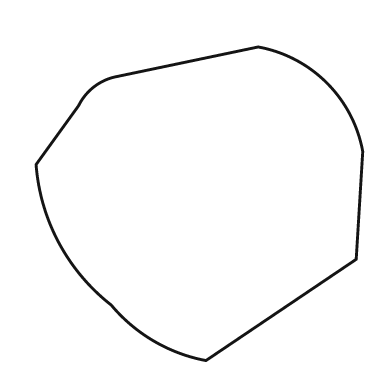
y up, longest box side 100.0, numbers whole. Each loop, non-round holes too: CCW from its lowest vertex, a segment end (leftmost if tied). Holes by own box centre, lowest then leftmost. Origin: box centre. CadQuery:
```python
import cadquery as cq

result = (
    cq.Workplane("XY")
    .moveTo(2.0, -48.0)
    .lineTo(48.0, -17.0)
    .lineTo(50.0, 16.0)
    .threePointArc((39.0, 37.0), (18.0, 48.0))
    .lineTo(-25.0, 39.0)
    .threePointArc((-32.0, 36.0), (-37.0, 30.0))
    .lineTo(-50.0, 12.0)
    .threePointArc((-43.0, -12.0), (-27.0, -31.0))
    .threePointArc((-14.0, -42.0), (2.0, -48.0))
    .close()
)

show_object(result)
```